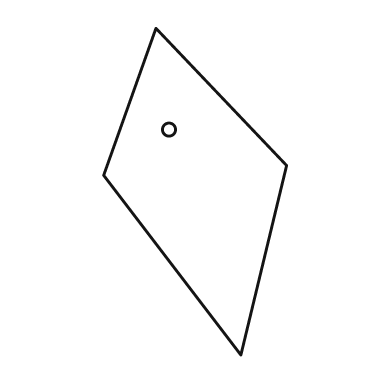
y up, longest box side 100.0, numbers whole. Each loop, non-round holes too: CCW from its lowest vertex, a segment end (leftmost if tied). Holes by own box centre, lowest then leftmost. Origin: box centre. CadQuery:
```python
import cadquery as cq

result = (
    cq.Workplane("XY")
    .moveTo(14.0, -50.0)
    .lineTo(28.0, 8.0)
    .lineTo(-12.0, 50.0)
    .lineTo(-28.0, 5.0)
    .close()
    .moveTo(-8.0, 19.0)
    .circle(2.0)
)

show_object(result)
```